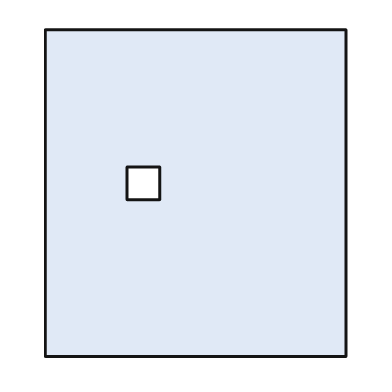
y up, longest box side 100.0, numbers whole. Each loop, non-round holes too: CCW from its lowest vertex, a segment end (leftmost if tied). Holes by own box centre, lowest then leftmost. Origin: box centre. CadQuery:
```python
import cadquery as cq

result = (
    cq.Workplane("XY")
    .moveTo(-46.0, -50.0)
    .lineTo(46.0, -50.0)
    .lineTo(46.0, 50.0)
    .lineTo(-46.0, 50.0)
    .close()
    .moveTo(-21.0, -2.0)
    .lineTo(-11.0, -2.0)
    .lineTo(-11.0, 8.0)
    .lineTo(-21.0, 8.0)
    .close()
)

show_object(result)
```